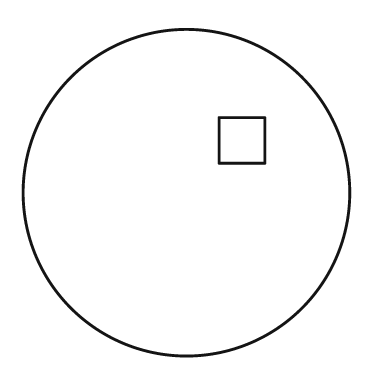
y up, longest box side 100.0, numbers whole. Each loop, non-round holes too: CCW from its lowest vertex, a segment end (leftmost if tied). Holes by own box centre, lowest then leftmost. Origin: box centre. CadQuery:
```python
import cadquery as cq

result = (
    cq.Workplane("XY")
    .moveTo(0.0, 0.0)
    .circle(50.0)
    .moveTo(10.0, 9.0)
    .lineTo(24.0, 9.0)
    .lineTo(24.0, 23.0)
    .lineTo(10.0, 23.0)
    .close()
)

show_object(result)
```